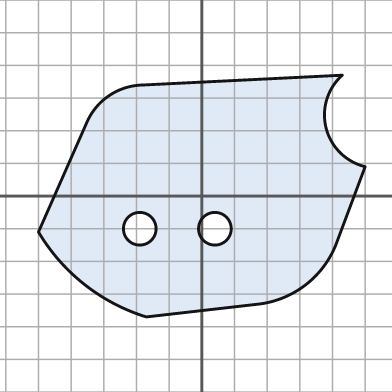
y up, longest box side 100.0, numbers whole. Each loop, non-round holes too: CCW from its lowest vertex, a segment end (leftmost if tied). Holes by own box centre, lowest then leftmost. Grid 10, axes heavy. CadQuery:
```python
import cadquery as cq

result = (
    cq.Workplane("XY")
    .moveTo(-17.0, -37.0)
    .lineTo(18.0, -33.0)
    .threePointArc((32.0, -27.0), (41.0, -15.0))
    .lineTo(50.0, 9.0)
    .threePointArc((38.0, 21.0), (43.0, 37.0))
    .lineTo(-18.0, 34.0)
    .threePointArc((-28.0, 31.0), (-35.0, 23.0))
    .lineTo(-50.0, -11.0)
    .threePointArc((-36.0, -27.0), (-17.0, -37.0))
    .close()
    .moveTo(-19.0, -10.0)
    .circle(5.0)
    .moveTo(4.0, -10.0)
    .circle(5.0)
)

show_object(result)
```